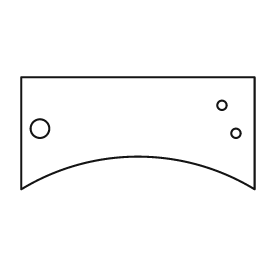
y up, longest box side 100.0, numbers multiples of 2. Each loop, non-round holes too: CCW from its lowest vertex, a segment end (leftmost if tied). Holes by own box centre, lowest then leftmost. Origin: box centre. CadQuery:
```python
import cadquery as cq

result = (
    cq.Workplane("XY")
    .moveTo(-50.0, -24.0)
    .threePointArc((0.0, -10.0), (50.0, -24.0))
    .lineTo(50.0, 24.0)
    .lineTo(-50.0, 24.0)
    .close()
    .moveTo(42.0, 0.0)
    .circle(2.0)
    .moveTo(-42.0, 2.0)
    .circle(4.0)
    .moveTo(36.0, 12.0)
    .circle(2.0)
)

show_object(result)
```